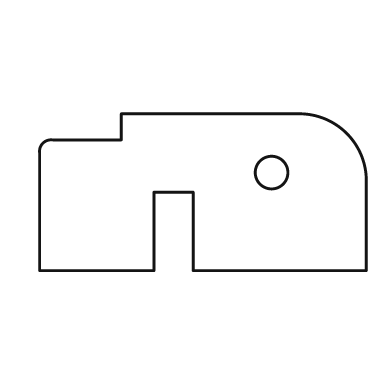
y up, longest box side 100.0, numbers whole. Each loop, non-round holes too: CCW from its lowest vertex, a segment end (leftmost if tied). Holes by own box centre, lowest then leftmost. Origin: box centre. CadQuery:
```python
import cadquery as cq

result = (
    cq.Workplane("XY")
    .moveTo(-50.0, -24.0)
    .lineTo(-15.0, -24.0)
    .lineTo(-15.0, 0.0)
    .lineTo(-3.0, 0.0)
    .lineTo(-3.0, -24.0)
    .lineTo(50.0, -24.0)
    .lineTo(50.0, 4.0)
    .threePointArc((44.0, 18.0), (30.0, 24.0))
    .lineTo(-25.0, 24.0)
    .lineTo(-25.0, 16.0)
    .lineTo(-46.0, 16.0)
    .threePointArc((-49.0, 15.0), (-50.0, 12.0))
    .close()
    .moveTo(21.0, 6.0)
    .circle(5.0)
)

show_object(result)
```